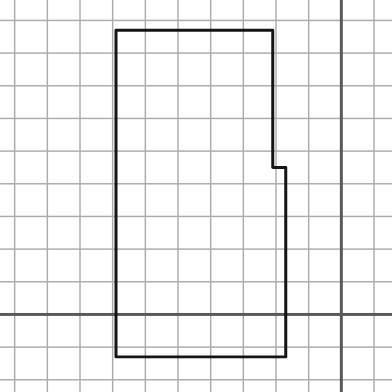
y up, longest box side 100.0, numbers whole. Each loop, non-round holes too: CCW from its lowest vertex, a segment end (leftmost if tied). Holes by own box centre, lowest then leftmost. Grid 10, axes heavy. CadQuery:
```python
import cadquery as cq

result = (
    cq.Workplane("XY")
    .moveTo(-69.0, -13.0)
    .lineTo(-17.0, -13.0)
    .lineTo(-17.0, 45.0)
    .lineTo(-21.0, 45.0)
    .lineTo(-21.0, 87.0)
    .lineTo(-69.0, 87.0)
    .close()
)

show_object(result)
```